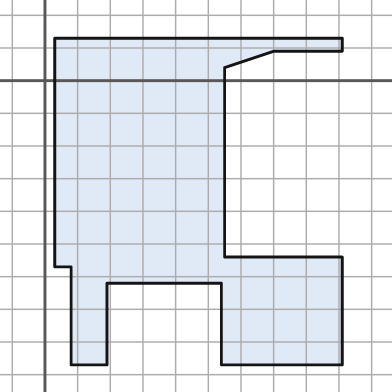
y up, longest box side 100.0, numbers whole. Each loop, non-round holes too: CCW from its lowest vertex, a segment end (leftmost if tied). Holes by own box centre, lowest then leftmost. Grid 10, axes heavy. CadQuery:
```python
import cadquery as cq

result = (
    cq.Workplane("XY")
    .moveTo(8.0, -87.0)
    .lineTo(19.0, -87.0)
    .lineTo(19.0, -62.0)
    .lineTo(54.0, -62.0)
    .lineTo(54.0, -87.0)
    .lineTo(91.0, -87.0)
    .lineTo(91.0, -54.0)
    .lineTo(55.0, -54.0)
    .lineTo(55.0, 4.0)
    .lineTo(70.0, 9.0)
    .lineTo(91.0, 9.0)
    .lineTo(91.0, 13.0)
    .lineTo(3.0, 13.0)
    .lineTo(3.0, -57.0)
    .lineTo(8.0, -57.0)
    .close()
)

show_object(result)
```